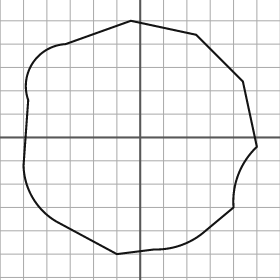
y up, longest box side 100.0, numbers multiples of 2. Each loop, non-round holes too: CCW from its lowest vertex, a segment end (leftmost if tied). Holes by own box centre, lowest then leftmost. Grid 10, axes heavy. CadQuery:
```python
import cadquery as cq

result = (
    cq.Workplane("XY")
    .moveTo(-10.0, -50.0)
    .lineTo(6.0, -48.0)
    .threePointArc((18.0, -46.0), (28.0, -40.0))
    .lineTo(40.0, -30.0)
    .threePointArc((42.0, -16.0), (50.0, -4.0))
    .lineTo(44.0, 24.0)
    .lineTo(24.0, 44.0)
    .lineTo(-4.0, 50.0)
    .lineTo(-32.0, 40.0)
    .threePointArc((-46.0, 32.0), (-48.0, 16.0))
    .lineTo(-50.0, -12.0)
    .threePointArc((-46.0, -26.0), (-36.0, -36.0))
    .close()
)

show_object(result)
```